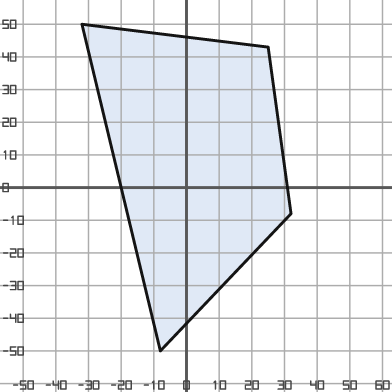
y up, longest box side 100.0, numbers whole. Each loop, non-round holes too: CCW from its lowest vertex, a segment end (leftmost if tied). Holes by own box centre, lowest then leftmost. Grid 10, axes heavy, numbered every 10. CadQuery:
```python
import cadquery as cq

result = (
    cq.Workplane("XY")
    .moveTo(-8.0, -50.0)
    .lineTo(32.0, -8.0)
    .lineTo(25.0, 43.0)
    .lineTo(-32.0, 50.0)
    .close()
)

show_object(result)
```